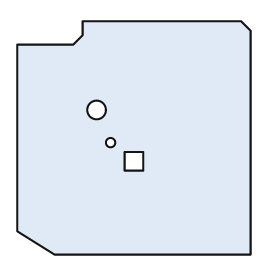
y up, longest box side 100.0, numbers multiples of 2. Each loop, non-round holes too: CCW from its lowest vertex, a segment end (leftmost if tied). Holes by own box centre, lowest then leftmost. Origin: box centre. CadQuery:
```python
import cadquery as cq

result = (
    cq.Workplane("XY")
    .moveTo(-34.0, -50.0)
    .lineTo(50.0, -50.0)
    .lineTo(50.0, 46.0)
    .lineTo(46.0, 50.0)
    .lineTo(-22.0, 50.0)
    .lineTo(-22.0, 44.0)
    .lineTo(-26.0, 40.0)
    .lineTo(-50.0, 40.0)
    .lineTo(-50.0, -40.0)
    .close()
    .moveTo(-4.0, -14.0)
    .lineTo(4.0, -14.0)
    .lineTo(4.0, -6.0)
    .lineTo(-4.0, -6.0)
    .close()
    .moveTo(-10.0, -2.0)
    .circle(2.0)
    .moveTo(-16.0, 12.0)
    .circle(4.0)
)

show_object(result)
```